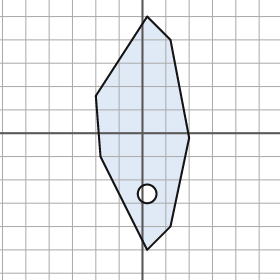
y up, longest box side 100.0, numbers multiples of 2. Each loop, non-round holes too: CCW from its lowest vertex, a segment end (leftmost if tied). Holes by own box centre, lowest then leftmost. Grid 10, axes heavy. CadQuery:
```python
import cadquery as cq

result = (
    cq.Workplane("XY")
    .moveTo(2.0, -50.0)
    .lineTo(12.0, -40.0)
    .lineTo(20.0, -2.0)
    .lineTo(12.0, 40.0)
    .lineTo(2.0, 50.0)
    .lineTo(-20.0, 16.0)
    .lineTo(-18.0, -10.0)
    .close()
    .moveTo(2.0, -26.0)
    .circle(4.0)
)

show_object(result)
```